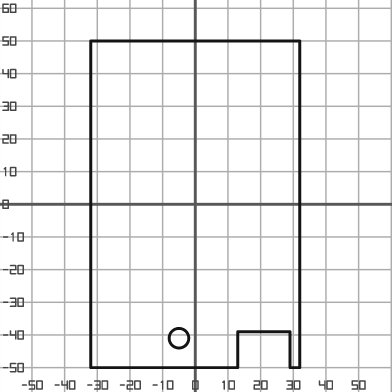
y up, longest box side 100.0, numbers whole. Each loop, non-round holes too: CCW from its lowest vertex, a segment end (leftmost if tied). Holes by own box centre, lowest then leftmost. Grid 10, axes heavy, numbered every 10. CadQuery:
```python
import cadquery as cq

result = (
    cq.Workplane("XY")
    .moveTo(-32.0, -50.0)
    .lineTo(13.0, -50.0)
    .lineTo(13.0, -39.0)
    .lineTo(29.0, -39.0)
    .lineTo(29.0, -50.0)
    .lineTo(32.0, -50.0)
    .lineTo(32.0, 50.0)
    .lineTo(-32.0, 50.0)
    .close()
    .moveTo(-5.0, -41.0)
    .circle(3.0)
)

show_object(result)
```